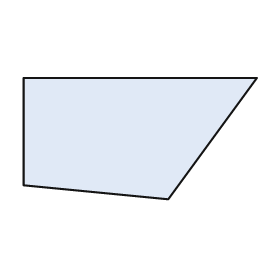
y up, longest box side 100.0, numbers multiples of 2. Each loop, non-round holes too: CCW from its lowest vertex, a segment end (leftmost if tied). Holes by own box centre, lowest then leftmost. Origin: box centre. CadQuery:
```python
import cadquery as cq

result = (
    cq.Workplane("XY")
    .moveTo(12.0, -26.0)
    .lineTo(50.0, 26.0)
    .lineTo(-50.0, 26.0)
    .lineTo(-50.0, -20.0)
    .close()
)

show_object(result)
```